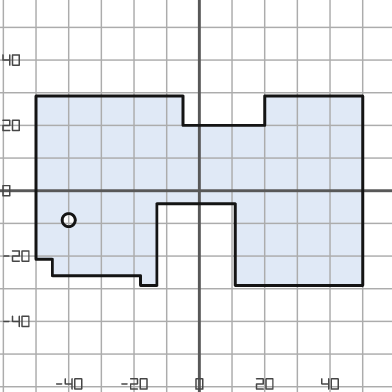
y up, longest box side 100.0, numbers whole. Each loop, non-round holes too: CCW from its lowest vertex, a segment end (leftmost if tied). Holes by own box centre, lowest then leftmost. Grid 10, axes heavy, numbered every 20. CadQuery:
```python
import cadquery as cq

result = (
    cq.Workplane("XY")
    .moveTo(-18.0, -29.0)
    .lineTo(-13.0, -29.0)
    .lineTo(-13.0, -4.0)
    .lineTo(11.0, -4.0)
    .lineTo(11.0, -29.0)
    .lineTo(50.0, -29.0)
    .lineTo(50.0, 29.0)
    .lineTo(20.0, 29.0)
    .lineTo(20.0, 20.0)
    .lineTo(-5.0, 20.0)
    .lineTo(-5.0, 29.0)
    .lineTo(-50.0, 29.0)
    .lineTo(-50.0, -21.0)
    .lineTo(-45.0, -21.0)
    .lineTo(-45.0, -26.0)
    .lineTo(-18.0, -26.0)
    .close()
    .moveTo(-40.0, -9.0)
    .circle(2.0)
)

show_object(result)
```